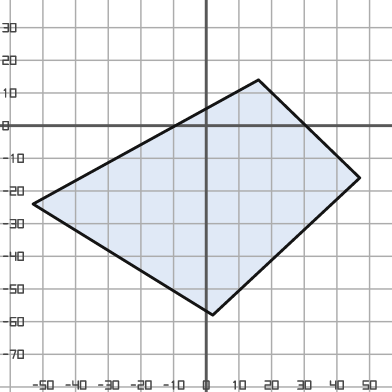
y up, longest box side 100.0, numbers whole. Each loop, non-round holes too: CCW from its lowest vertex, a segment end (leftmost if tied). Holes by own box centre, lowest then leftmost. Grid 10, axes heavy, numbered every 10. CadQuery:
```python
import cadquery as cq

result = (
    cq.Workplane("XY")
    .moveTo(2.0, -58.0)
    .lineTo(47.0, -16.0)
    .lineTo(16.0, 14.0)
    .lineTo(-53.0, -24.0)
    .close()
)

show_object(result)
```